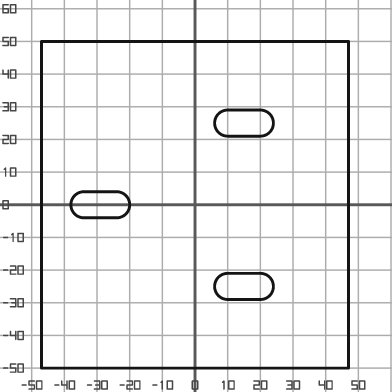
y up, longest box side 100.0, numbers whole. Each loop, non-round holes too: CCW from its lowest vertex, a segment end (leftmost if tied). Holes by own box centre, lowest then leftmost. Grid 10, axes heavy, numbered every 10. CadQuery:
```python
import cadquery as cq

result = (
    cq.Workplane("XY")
    .moveTo(-47.0, -50.0)
    .lineTo(47.0, -50.0)
    .lineTo(47.0, 50.0)
    .lineTo(-47.0, 50.0)
    .close()
    .moveTo(10.0, -29.0)
    .lineTo(20.0, -29.0)
    .threePointArc((24.0, -25.0), (20.0, -21.0))
    .lineTo(10.0, -21.0)
    .threePointArc((6.0, -25.0), (10.0, -29.0))
    .close()
    .moveTo(-34.0, -4.0)
    .lineTo(-24.0, -4.0)
    .threePointArc((-20.0, 0.0), (-24.0, 4.0))
    .lineTo(-34.0, 4.0)
    .threePointArc((-38.0, 0.0), (-34.0, -4.0))
    .close()
    .moveTo(10.0, 21.0)
    .lineTo(20.0, 21.0)
    .threePointArc((24.0, 25.0), (20.0, 29.0))
    .lineTo(10.0, 29.0)
    .threePointArc((6.0, 25.0), (10.0, 21.0))
    .close()
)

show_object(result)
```